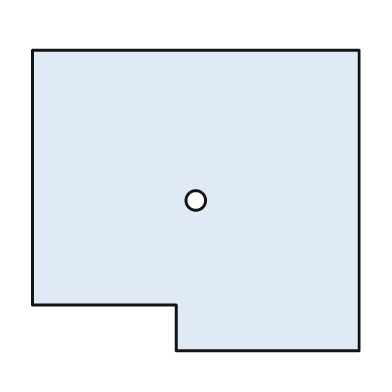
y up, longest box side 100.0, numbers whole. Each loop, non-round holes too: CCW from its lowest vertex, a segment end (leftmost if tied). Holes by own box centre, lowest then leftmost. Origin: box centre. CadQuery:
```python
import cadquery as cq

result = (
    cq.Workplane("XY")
    .moveTo(-6.0, -46.0)
    .lineTo(50.0, -46.0)
    .lineTo(50.0, 46.0)
    .lineTo(-50.0, 46.0)
    .lineTo(-50.0, -32.0)
    .lineTo(-6.0, -32.0)
    .close()
    .moveTo(0.0, 0.0)
    .circle(3.0)
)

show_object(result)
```